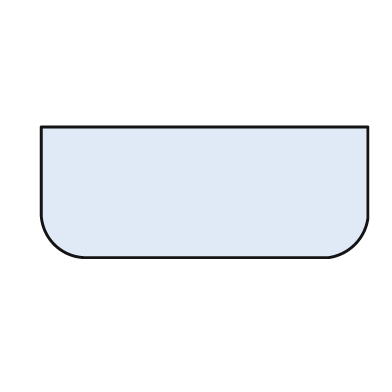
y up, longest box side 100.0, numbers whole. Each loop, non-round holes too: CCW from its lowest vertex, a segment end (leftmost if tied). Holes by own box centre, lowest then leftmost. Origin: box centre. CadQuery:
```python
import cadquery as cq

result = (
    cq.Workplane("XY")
    .moveTo(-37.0, -20.0)
    .lineTo(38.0, -20.0)
    .threePointArc((46.0, -16.0), (50.0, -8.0))
    .lineTo(50.0, 20.0)
    .lineTo(-50.0, 20.0)
    .lineTo(-50.0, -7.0)
    .threePointArc((-46.0, -16.0), (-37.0, -20.0))
    .close()
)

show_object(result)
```